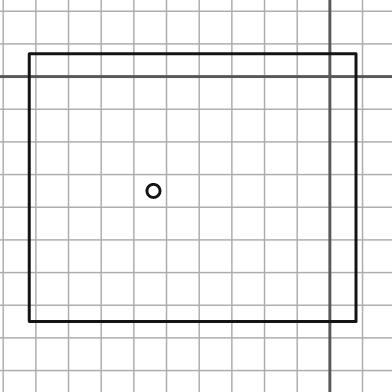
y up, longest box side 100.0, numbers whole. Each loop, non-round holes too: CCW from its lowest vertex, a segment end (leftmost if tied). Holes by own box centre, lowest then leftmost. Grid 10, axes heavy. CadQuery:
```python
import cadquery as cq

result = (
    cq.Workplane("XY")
    .moveTo(-92.0, -75.0)
    .lineTo(8.0, -75.0)
    .lineTo(8.0, 7.0)
    .lineTo(-92.0, 7.0)
    .close()
    .moveTo(-54.0, -35.0)
    .circle(2.0)
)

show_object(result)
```